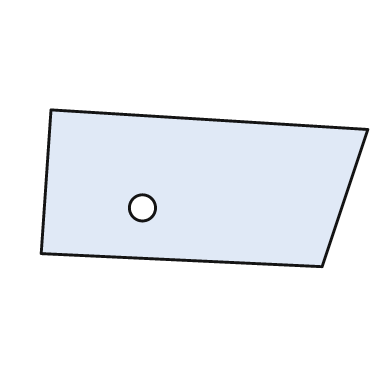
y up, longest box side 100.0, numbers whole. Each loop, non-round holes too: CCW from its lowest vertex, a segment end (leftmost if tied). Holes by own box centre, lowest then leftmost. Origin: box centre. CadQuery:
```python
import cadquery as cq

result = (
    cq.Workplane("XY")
    .moveTo(36.0, -24.0)
    .lineTo(50.0, 18.0)
    .lineTo(-47.0, 24.0)
    .lineTo(-50.0, -20.0)
    .close()
    .moveTo(-19.0, -6.0)
    .circle(4.0)
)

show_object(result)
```